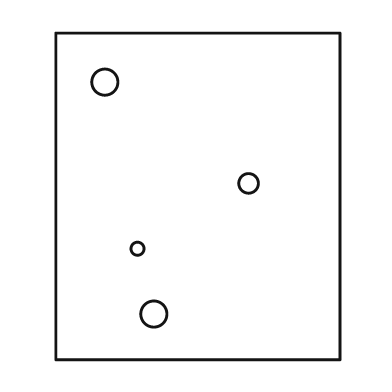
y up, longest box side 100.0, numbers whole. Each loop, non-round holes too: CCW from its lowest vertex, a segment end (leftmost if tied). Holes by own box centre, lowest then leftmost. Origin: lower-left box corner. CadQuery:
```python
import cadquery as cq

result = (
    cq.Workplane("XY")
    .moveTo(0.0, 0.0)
    .lineTo(87.0, 0.0)
    .lineTo(87.0, 100.0)
    .lineTo(0.0, 100.0)
    .close()
    .moveTo(30.0, 14.0)
    .circle(4.0)
    .moveTo(25.0, 34.0)
    .circle(2.0)
    .moveTo(59.0, 54.0)
    .circle(3.0)
    .moveTo(15.0, 85.0)
    .circle(4.0)
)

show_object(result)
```